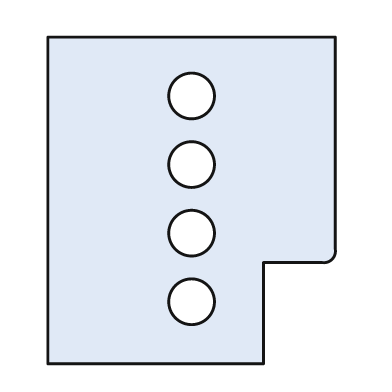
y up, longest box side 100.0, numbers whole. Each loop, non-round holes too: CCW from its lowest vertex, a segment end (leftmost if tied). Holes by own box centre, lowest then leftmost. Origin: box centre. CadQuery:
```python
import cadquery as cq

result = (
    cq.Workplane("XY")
    .moveTo(-44.0, -50.0)
    .lineTo(22.0, -50.0)
    .lineTo(22.0, -19.0)
    .lineTo(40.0, -19.0)
    .threePointArc((43.0, -18.0), (44.0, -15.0))
    .lineTo(44.0, 50.0)
    .lineTo(-44.0, 50.0)
    .close()
    .moveTo(0.0, -31.0)
    .circle(7.0)
    .moveTo(0.0, -10.0)
    .circle(7.0)
    .moveTo(0.0, 11.0)
    .circle(7.0)
    .moveTo(0.0, 32.0)
    .circle(7.0)
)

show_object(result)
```